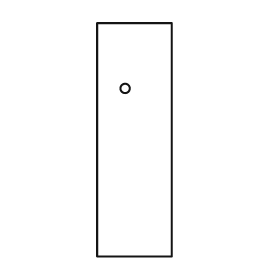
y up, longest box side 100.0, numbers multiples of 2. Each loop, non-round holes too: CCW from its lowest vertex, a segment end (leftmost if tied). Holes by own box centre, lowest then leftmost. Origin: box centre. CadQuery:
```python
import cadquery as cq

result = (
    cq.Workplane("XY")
    .moveTo(-16.0, -50.0)
    .lineTo(16.0, -50.0)
    .lineTo(16.0, 50.0)
    .lineTo(-16.0, 50.0)
    .close()
    .moveTo(-4.0, 22.0)
    .circle(2.0)
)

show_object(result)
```